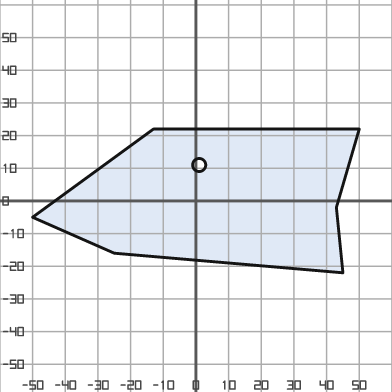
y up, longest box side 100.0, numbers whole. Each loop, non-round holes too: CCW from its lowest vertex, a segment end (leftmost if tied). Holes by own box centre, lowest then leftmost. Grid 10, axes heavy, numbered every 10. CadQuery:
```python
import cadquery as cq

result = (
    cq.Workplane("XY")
    .moveTo(45.0, -22.0)
    .lineTo(43.0, -2.0)
    .lineTo(50.0, 22.0)
    .lineTo(-13.0, 22.0)
    .lineTo(-50.0, -5.0)
    .lineTo(-25.0, -16.0)
    .close()
    .moveTo(1.0, 11.0)
    .circle(2.0)
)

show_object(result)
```